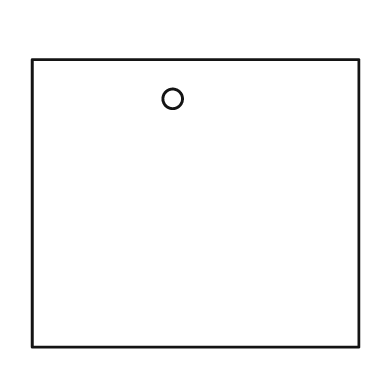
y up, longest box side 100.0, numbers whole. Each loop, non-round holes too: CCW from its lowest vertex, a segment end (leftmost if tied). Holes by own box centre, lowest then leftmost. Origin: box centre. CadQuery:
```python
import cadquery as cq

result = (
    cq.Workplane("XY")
    .moveTo(-50.0, -44.0)
    .lineTo(50.0, -44.0)
    .lineTo(50.0, 44.0)
    .lineTo(-50.0, 44.0)
    .close()
    .moveTo(-7.0, 32.0)
    .circle(3.0)
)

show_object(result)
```